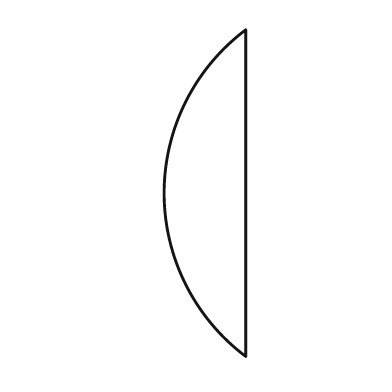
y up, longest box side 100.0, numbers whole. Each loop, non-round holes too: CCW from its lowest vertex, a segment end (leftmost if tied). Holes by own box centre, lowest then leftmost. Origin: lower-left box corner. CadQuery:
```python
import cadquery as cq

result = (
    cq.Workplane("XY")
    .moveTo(25.0, 0.0)
    .lineTo(25.0, 100.0)
    .threePointArc((0.0, 50.0), (25.0, 0.0))
    .close()
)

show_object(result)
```